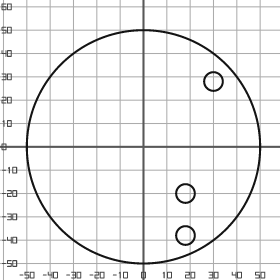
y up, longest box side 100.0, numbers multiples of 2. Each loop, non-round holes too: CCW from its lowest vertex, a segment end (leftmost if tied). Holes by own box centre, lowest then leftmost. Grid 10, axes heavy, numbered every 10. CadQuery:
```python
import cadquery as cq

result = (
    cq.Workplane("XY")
    .moveTo(0.0, 0.0)
    .circle(50.0)
    .moveTo(18.0, -38.0)
    .circle(4.0)
    .moveTo(18.0, -20.0)
    .circle(4.0)
    .moveTo(30.0, 28.0)
    .circle(4.0)
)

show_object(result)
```